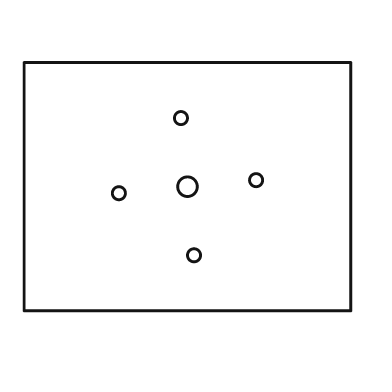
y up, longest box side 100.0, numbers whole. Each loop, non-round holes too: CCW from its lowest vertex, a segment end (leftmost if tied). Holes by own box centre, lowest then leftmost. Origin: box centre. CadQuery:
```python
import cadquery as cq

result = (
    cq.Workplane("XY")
    .moveTo(-50.0, -38.0)
    .lineTo(50.0, -38.0)
    .lineTo(50.0, 38.0)
    .lineTo(-50.0, 38.0)
    .close()
    .moveTo(2.0, -21.0)
    .circle(2.0)
    .moveTo(-21.0, -2.0)
    .circle(2.0)
    .moveTo(0.0, 0.0)
    .circle(3.0)
    .moveTo(21.0, 2.0)
    .circle(2.0)
    .moveTo(-2.0, 21.0)
    .circle(2.0)
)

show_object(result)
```